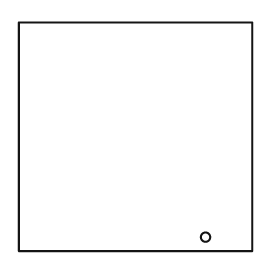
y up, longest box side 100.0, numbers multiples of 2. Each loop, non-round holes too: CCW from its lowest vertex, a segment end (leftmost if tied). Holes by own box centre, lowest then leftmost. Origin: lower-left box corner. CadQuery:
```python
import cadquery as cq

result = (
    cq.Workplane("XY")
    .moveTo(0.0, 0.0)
    .lineTo(100.0, 0.0)
    .lineTo(100.0, 98.0)
    .lineTo(0.0, 98.0)
    .close()
    .moveTo(80.0, 6.0)
    .circle(2.0)
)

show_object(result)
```